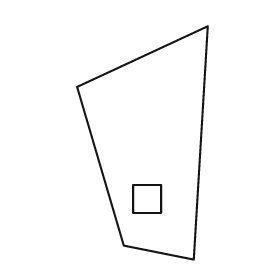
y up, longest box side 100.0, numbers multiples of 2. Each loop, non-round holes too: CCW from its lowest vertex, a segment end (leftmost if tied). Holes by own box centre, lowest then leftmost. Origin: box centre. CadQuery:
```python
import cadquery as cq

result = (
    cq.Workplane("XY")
    .moveTo(22.0, -50.0)
    .lineTo(28.0, 50.0)
    .lineTo(-28.0, 24.0)
    .lineTo(-8.0, -44.0)
    .close()
    .moveTo(-4.0, -30.0)
    .lineTo(8.0, -30.0)
    .lineTo(8.0, -18.0)
    .lineTo(-4.0, -18.0)
    .close()
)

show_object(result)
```